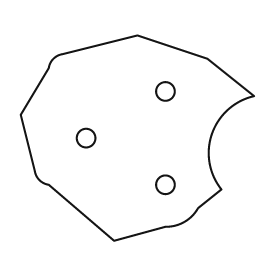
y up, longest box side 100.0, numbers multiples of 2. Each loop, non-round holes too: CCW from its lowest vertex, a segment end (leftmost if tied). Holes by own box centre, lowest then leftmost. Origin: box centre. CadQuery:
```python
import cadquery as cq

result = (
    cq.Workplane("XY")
    .moveTo(-10.0, -44.0)
    .lineTo(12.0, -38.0)
    .threePointArc((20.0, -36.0), (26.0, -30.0))
    .lineTo(36.0, -22.0)
    .threePointArc((32.0, 2.0), (50.0, 18.0))
    .lineTo(30.0, 34.0)
    .lineTo(0.0, 44.0)
    .lineTo(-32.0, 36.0)
    .threePointArc((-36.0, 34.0), (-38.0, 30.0))
    .lineTo(-50.0, 10.0)
    .lineTo(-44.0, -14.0)
    .threePointArc((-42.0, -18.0), (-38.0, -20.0))
    .close()
    .moveTo(12.0, -20.0)
    .circle(4.0)
    .moveTo(-22.0, 0.0)
    .circle(4.0)
    .moveTo(12.0, 20.0)
    .circle(4.0)
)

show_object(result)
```